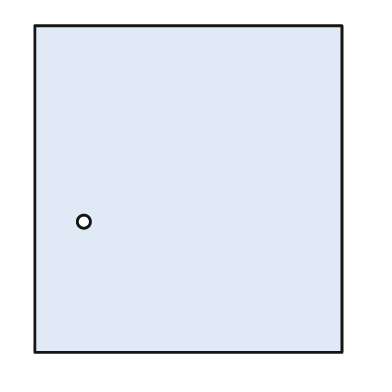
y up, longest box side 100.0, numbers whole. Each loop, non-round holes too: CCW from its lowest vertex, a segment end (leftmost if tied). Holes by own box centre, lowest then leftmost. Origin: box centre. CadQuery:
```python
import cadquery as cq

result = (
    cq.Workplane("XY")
    .moveTo(-47.0, -50.0)
    .lineTo(47.0, -50.0)
    .lineTo(47.0, 50.0)
    .lineTo(-47.0, 50.0)
    .close()
    .moveTo(-32.0, -10.0)
    .circle(2.0)
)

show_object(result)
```